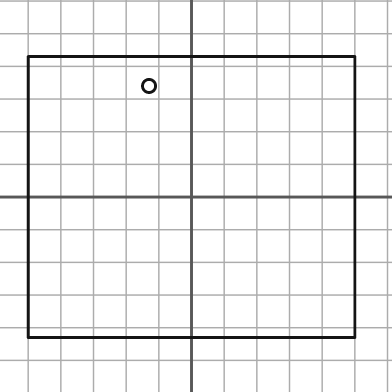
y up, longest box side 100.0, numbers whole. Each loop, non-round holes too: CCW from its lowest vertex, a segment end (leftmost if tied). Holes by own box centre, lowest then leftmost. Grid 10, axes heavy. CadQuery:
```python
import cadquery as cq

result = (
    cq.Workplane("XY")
    .moveTo(-50.0, -43.0)
    .lineTo(50.0, -43.0)
    .lineTo(50.0, 43.0)
    .lineTo(-50.0, 43.0)
    .close()
    .moveTo(-13.0, 34.0)
    .circle(2.0)
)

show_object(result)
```